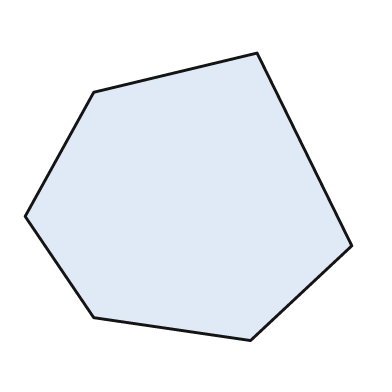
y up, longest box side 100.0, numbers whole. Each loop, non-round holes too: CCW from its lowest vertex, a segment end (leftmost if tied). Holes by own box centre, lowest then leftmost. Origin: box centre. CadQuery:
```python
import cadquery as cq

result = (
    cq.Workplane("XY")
    .moveTo(19.0, -44.0)
    .lineTo(50.0, -15.0)
    .lineTo(21.0, 44.0)
    .lineTo(-29.0, 32.0)
    .lineTo(-50.0, -6.0)
    .lineTo(-29.0, -37.0)
    .close()
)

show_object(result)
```